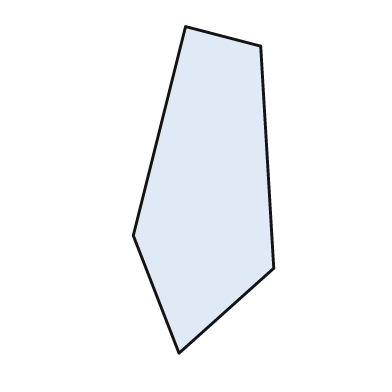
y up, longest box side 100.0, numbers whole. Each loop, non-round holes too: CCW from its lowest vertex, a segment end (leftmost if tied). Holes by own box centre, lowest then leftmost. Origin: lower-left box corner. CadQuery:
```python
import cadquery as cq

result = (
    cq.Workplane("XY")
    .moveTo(14.0, 0.0)
    .lineTo(43.0, 26.0)
    .lineTo(39.0, 94.0)
    .lineTo(16.0, 100.0)
    .lineTo(0.0, 36.0)
    .close()
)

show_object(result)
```